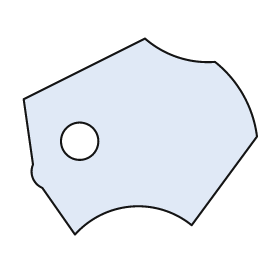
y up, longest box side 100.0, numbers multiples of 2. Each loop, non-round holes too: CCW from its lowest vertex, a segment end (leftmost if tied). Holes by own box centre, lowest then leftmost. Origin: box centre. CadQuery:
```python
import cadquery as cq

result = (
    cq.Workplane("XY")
    .moveTo(-28.0, -42.0)
    .threePointArc((-4.0, -30.0), (22.0, -38.0))
    .lineTo(50.0, 0.0)
    .threePointArc((44.0, 18.0), (32.0, 32.0))
    .threePointArc((16.0, 34.0), (2.0, 42.0))
    .lineTo(-50.0, 16.0)
    .lineTo(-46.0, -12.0)
    .threePointArc((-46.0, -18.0), (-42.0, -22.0))
    .close()
    .moveTo(-26.0, -2.0)
    .circle(8.0)
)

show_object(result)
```